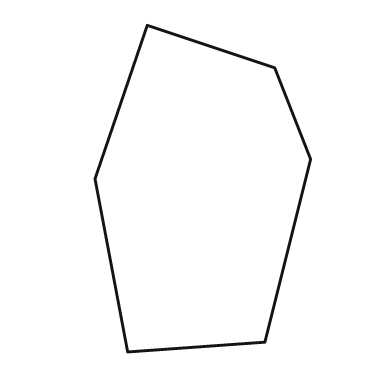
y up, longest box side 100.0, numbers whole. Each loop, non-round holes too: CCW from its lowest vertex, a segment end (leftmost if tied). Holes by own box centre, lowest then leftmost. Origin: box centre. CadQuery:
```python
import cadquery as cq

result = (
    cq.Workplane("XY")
    .moveTo(-23.0, -50.0)
    .lineTo(19.0, -47.0)
    .lineTo(33.0, 9.0)
    .lineTo(22.0, 37.0)
    .lineTo(-17.0, 50.0)
    .lineTo(-33.0, 3.0)
    .close()
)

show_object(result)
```